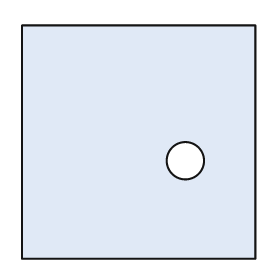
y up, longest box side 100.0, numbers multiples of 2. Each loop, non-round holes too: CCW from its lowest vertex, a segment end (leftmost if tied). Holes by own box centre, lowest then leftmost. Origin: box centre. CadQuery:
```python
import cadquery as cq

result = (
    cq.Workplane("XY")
    .moveTo(-50.0, -50.0)
    .lineTo(50.0, -50.0)
    .lineTo(50.0, 50.0)
    .lineTo(-50.0, 50.0)
    .close()
    .moveTo(20.0, -8.0)
    .circle(8.0)
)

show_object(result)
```